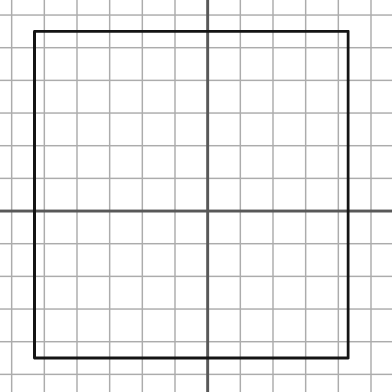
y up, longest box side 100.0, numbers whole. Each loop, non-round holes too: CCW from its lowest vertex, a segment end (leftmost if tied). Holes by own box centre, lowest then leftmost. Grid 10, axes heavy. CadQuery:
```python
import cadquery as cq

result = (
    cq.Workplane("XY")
    .moveTo(-53.0, -45.0)
    .lineTo(43.0, -45.0)
    .lineTo(43.0, 55.0)
    .lineTo(-53.0, 55.0)
    .close()
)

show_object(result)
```